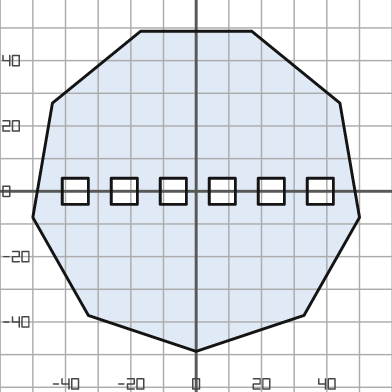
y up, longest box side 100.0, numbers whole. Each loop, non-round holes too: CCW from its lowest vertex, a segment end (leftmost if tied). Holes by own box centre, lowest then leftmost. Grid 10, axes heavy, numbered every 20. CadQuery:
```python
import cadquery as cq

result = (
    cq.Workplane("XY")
    .moveTo(0.0, -49.0)
    .lineTo(33.0, -38.0)
    .lineTo(50.0, -8.0)
    .lineTo(44.0, 27.0)
    .lineTo(17.0, 49.0)
    .lineTo(-17.0, 49.0)
    .lineTo(-44.0, 27.0)
    .lineTo(-50.0, -8.0)
    .lineTo(-33.0, -38.0)
    .close()
    .moveTo(-41.0, -4.0)
    .lineTo(-33.0, -4.0)
    .lineTo(-33.0, 4.0)
    .lineTo(-41.0, 4.0)
    .close()
    .moveTo(-26.0, -4.0)
    .lineTo(-18.0, -4.0)
    .lineTo(-18.0, 4.0)
    .lineTo(-26.0, 4.0)
    .close()
    .moveTo(-11.0, -4.0)
    .lineTo(-3.0, -4.0)
    .lineTo(-3.0, 4.0)
    .lineTo(-11.0, 4.0)
    .close()
    .moveTo(4.0, -4.0)
    .lineTo(12.0, -4.0)
    .lineTo(12.0, 4.0)
    .lineTo(4.0, 4.0)
    .close()
    .moveTo(19.0, -4.0)
    .lineTo(27.0, -4.0)
    .lineTo(27.0, 4.0)
    .lineTo(19.0, 4.0)
    .close()
    .moveTo(34.0, -4.0)
    .lineTo(42.0, -4.0)
    .lineTo(42.0, 4.0)
    .lineTo(34.0, 4.0)
    .close()
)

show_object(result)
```